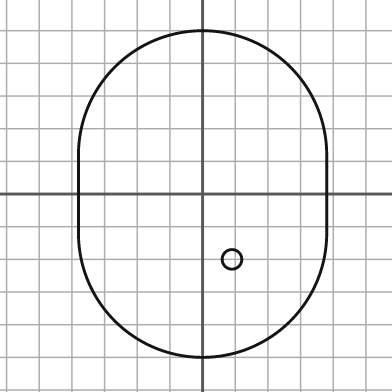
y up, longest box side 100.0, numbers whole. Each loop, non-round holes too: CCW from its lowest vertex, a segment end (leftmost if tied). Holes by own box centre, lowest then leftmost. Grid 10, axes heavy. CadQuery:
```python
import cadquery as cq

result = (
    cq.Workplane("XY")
    .moveTo(-38.0, -12.0)
    .threePointArc((0.0, -50.0), (38.0, -12.0))
    .lineTo(38.0, 12.0)
    .threePointArc((0.0, 50.0), (-38.0, 12.0))
    .close()
    .moveTo(9.0, -20.0)
    .circle(3.0)
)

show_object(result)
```